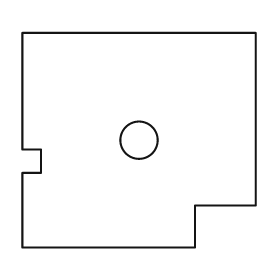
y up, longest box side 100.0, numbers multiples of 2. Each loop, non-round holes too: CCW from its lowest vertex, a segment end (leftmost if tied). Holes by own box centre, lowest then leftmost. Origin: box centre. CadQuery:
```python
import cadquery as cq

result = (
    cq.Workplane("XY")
    .moveTo(-50.0, -46.0)
    .lineTo(24.0, -46.0)
    .lineTo(24.0, -28.0)
    .lineTo(50.0, -28.0)
    .lineTo(50.0, 46.0)
    .lineTo(-50.0, 46.0)
    .lineTo(-50.0, -4.0)
    .lineTo(-42.0, -4.0)
    .lineTo(-42.0, -14.0)
    .lineTo(-50.0, -14.0)
    .close()
    .moveTo(0.0, 0.0)
    .circle(8.0)
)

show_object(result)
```